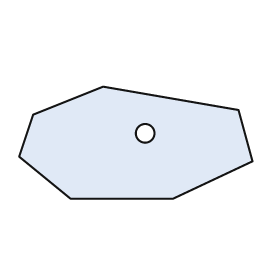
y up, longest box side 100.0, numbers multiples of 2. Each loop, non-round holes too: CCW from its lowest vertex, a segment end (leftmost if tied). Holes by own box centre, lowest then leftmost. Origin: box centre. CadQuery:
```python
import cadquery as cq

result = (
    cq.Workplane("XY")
    .moveTo(-28.0, -24.0)
    .lineTo(16.0, -24.0)
    .lineTo(50.0, -8.0)
    .lineTo(44.0, 14.0)
    .lineTo(-14.0, 24.0)
    .lineTo(-44.0, 12.0)
    .lineTo(-50.0, -6.0)
    .close()
    .moveTo(4.0, 4.0)
    .circle(4.0)
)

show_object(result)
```